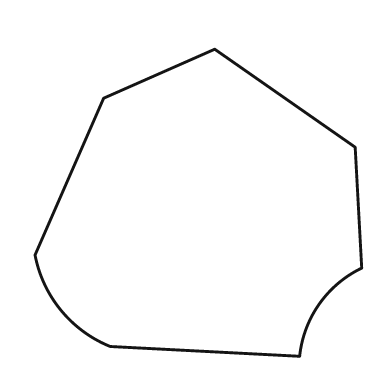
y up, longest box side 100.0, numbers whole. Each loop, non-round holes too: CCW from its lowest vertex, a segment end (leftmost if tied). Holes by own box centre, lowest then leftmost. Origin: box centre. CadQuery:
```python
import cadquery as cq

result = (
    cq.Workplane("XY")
    .moveTo(31.0, -47.0)
    .threePointArc((37.0, -31.0), (50.0, -20.0))
    .lineTo(48.0, 17.0)
    .lineTo(5.0, 47.0)
    .lineTo(-29.0, 32.0)
    .lineTo(-50.0, -16.0)
    .threePointArc((-42.0, -33.0), (-27.0, -44.0))
    .close()
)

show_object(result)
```